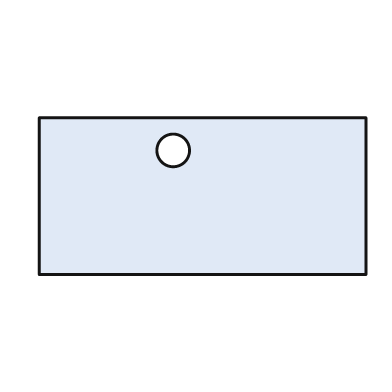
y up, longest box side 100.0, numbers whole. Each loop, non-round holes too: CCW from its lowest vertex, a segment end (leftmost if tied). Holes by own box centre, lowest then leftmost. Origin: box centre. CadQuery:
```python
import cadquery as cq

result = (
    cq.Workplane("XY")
    .moveTo(-50.0, -24.0)
    .lineTo(50.0, -24.0)
    .lineTo(50.0, 24.0)
    .lineTo(-50.0, 24.0)
    .close()
    .moveTo(-9.0, 14.0)
    .circle(5.0)
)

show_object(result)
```